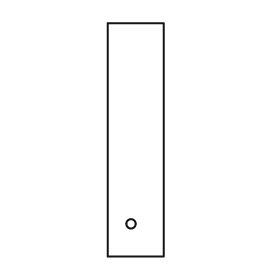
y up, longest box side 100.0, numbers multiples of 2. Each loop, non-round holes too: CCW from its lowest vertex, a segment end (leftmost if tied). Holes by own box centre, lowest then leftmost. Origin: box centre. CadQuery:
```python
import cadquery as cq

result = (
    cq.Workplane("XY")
    .moveTo(-12.0, -50.0)
    .lineTo(12.0, -50.0)
    .lineTo(12.0, 50.0)
    .lineTo(-12.0, 50.0)
    .close()
    .moveTo(-2.0, -36.0)
    .circle(2.0)
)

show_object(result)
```